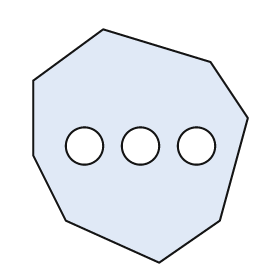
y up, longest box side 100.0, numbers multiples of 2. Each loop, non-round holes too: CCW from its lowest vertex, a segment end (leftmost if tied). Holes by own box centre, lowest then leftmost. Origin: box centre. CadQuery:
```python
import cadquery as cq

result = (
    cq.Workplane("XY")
    .moveTo(8.0, -50.0)
    .lineTo(34.0, -32.0)
    .lineTo(46.0, 12.0)
    .lineTo(30.0, 36.0)
    .lineTo(-16.0, 50.0)
    .lineTo(-46.0, 28.0)
    .lineTo(-46.0, -4.0)
    .lineTo(-32.0, -32.0)
    .close()
    .moveTo(-24.0, 0.0)
    .circle(8.0)
    .moveTo(0.0, 0.0)
    .circle(8.0)
    .moveTo(24.0, 0.0)
    .circle(8.0)
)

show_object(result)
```